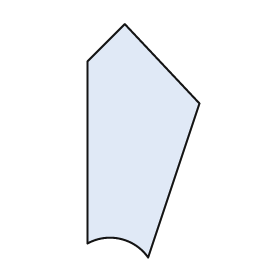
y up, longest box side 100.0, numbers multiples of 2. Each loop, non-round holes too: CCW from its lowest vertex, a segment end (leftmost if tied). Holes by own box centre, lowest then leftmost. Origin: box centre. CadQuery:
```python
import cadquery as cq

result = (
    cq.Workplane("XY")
    .moveTo(2.0, -50.0)
    .lineTo(24.0, 16.0)
    .lineTo(-8.0, 50.0)
    .lineTo(-24.0, 34.0)
    .lineTo(-24.0, -44.0)
    .threePointArc((-10.0, -42.0), (2.0, -50.0))
    .close()
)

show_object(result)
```